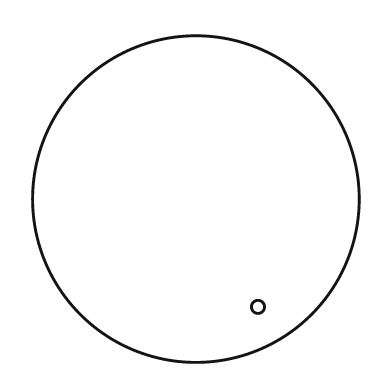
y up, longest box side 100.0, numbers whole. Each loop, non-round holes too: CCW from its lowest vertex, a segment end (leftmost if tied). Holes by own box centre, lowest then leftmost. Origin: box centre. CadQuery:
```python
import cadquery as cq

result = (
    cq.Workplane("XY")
    .moveTo(0.0, 0.0)
    .circle(50.0)
    .moveTo(19.0, -33.0)
    .circle(2.0)
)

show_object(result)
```